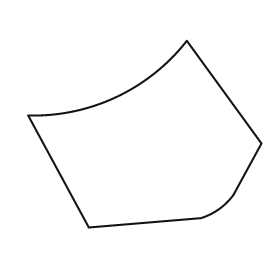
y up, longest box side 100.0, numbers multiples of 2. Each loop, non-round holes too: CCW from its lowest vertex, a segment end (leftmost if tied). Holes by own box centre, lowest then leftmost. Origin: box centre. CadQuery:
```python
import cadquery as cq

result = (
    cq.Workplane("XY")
    .moveTo(-24.0, -40.0)
    .lineTo(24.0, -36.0)
    .threePointArc((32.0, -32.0), (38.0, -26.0))
    .lineTo(50.0, -4.0)
    .lineTo(18.0, 40.0)
    .threePointArc((-12.0, 16.0), (-50.0, 8.0))
    .close()
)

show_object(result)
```